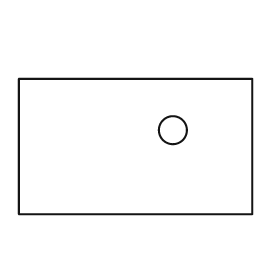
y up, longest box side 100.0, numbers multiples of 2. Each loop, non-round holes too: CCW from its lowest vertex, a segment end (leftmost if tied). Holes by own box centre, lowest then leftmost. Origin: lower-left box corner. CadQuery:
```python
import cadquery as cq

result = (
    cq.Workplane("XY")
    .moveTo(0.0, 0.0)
    .lineTo(100.0, 0.0)
    .lineTo(100.0, 58.0)
    .lineTo(0.0, 58.0)
    .close()
    .moveTo(66.0, 36.0)
    .circle(6.0)
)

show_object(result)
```